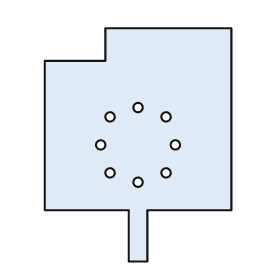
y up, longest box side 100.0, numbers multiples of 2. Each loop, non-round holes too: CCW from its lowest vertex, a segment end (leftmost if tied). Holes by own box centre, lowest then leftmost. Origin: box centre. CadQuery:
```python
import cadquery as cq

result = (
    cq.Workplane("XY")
    .moveTo(-4.0, -50.0)
    .lineTo(4.0, -50.0)
    .lineTo(4.0, -28.0)
    .lineTo(40.0, -28.0)
    .lineTo(40.0, 50.0)
    .lineTo(-14.0, 50.0)
    .lineTo(-14.0, 36.0)
    .lineTo(-40.0, 36.0)
    .lineTo(-40.0, -28.0)
    .lineTo(-4.0, -28.0)
    .close()
    .moveTo(0.0, -16.0)
    .circle(2.0)
    .moveTo(-12.0, -12.0)
    .circle(2.0)
    .moveTo(12.0, -12.0)
    .circle(2.0)
    .moveTo(-16.0, 0.0)
    .circle(2.0)
    .moveTo(16.0, 0.0)
    .circle(2.0)
    .moveTo(-12.0, 12.0)
    .circle(2.0)
    .moveTo(12.0, 12.0)
    .circle(2.0)
    .moveTo(0.0, 16.0)
    .circle(2.0)
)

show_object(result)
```